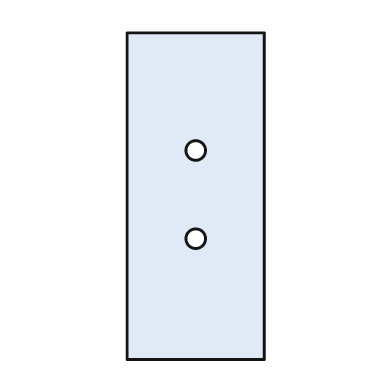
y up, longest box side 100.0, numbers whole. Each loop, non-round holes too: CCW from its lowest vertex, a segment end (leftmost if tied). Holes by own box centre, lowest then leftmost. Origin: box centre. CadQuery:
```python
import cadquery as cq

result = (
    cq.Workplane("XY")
    .moveTo(-21.0, -50.0)
    .lineTo(21.0, -50.0)
    .lineTo(21.0, 50.0)
    .lineTo(-21.0, 50.0)
    .close()
    .moveTo(0.0, -13.0)
    .circle(3.0)
    .moveTo(0.0, 14.0)
    .circle(3.0)
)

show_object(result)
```